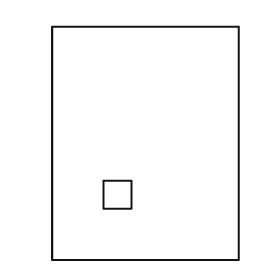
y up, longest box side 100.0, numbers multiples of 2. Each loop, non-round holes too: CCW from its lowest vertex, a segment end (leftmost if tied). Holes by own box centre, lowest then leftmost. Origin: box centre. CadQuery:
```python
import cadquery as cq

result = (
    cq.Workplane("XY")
    .moveTo(-40.0, -50.0)
    .lineTo(40.0, -50.0)
    .lineTo(40.0, 50.0)
    .lineTo(-40.0, 50.0)
    .close()
    .moveTo(-18.0, -28.0)
    .lineTo(-6.0, -28.0)
    .lineTo(-6.0, -16.0)
    .lineTo(-18.0, -16.0)
    .close()
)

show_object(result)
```